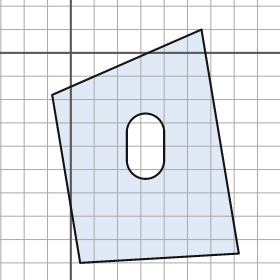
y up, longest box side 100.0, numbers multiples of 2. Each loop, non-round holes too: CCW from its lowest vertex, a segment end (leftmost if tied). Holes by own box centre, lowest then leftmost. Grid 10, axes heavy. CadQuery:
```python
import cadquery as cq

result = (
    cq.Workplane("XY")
    .moveTo(4.0, -90.0)
    .lineTo(72.0, -86.0)
    .lineTo(56.0, 10.0)
    .lineTo(-8.0, -18.0)
    .close()
    .moveTo(24.0, -46.0)
    .threePointArc((32.0, -54.0), (40.0, -46.0))
    .lineTo(40.0, -34.0)
    .threePointArc((32.0, -26.0), (24.0, -34.0))
    .close()
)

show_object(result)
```